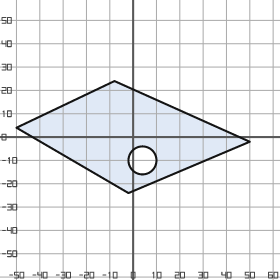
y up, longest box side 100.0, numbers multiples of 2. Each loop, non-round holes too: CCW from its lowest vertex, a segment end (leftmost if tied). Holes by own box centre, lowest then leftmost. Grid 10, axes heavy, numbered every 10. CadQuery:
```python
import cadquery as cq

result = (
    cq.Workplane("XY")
    .moveTo(-2.0, -24.0)
    .lineTo(50.0, -2.0)
    .lineTo(-8.0, 24.0)
    .lineTo(-50.0, 4.0)
    .close()
    .moveTo(4.0, -10.0)
    .circle(6.0)
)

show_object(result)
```